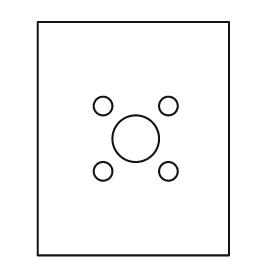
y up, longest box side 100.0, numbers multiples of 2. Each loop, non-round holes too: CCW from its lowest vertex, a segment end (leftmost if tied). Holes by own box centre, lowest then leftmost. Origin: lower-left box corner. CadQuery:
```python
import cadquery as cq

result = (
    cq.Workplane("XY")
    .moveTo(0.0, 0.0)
    .lineTo(82.0, 0.0)
    .lineTo(82.0, 100.0)
    .lineTo(0.0, 100.0)
    .close()
    .moveTo(28.0, 36.0)
    .circle(4.0)
    .moveTo(56.0, 36.0)
    .circle(4.0)
    .moveTo(42.0, 50.0)
    .circle(10.0)
    .moveTo(28.0, 64.0)
    .circle(4.0)
    .moveTo(56.0, 64.0)
    .circle(4.0)
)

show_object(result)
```